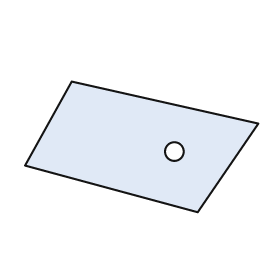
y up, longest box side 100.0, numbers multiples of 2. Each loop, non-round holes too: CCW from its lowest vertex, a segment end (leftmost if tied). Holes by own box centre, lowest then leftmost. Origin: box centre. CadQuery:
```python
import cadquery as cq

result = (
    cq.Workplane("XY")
    .moveTo(24.0, -28.0)
    .lineTo(50.0, 10.0)
    .lineTo(-30.0, 28.0)
    .lineTo(-50.0, -8.0)
    .close()
    .moveTo(14.0, -2.0)
    .circle(4.0)
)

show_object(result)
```